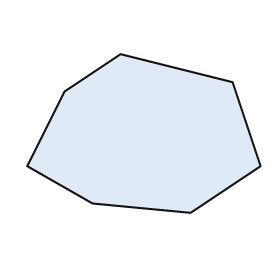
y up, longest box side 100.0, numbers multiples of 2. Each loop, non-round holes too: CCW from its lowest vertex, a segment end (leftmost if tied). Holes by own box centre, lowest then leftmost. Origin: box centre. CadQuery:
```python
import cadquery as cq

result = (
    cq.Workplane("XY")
    .moveTo(20.0, -34.0)
    .lineTo(50.0, -14.0)
    .lineTo(38.0, 22.0)
    .lineTo(-10.0, 34.0)
    .lineTo(-34.0, 18.0)
    .lineTo(-50.0, -14.0)
    .lineTo(-22.0, -30.0)
    .close()
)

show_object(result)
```